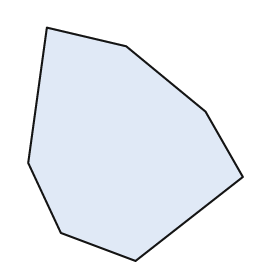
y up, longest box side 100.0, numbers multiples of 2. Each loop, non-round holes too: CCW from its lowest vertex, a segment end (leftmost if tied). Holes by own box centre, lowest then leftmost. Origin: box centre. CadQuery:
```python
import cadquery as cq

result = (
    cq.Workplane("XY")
    .moveTo(0.0, -50.0)
    .lineTo(46.0, -14.0)
    .lineTo(30.0, 14.0)
    .lineTo(-4.0, 42.0)
    .lineTo(-38.0, 50.0)
    .lineTo(-46.0, -8.0)
    .lineTo(-32.0, -38.0)
    .close()
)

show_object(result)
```